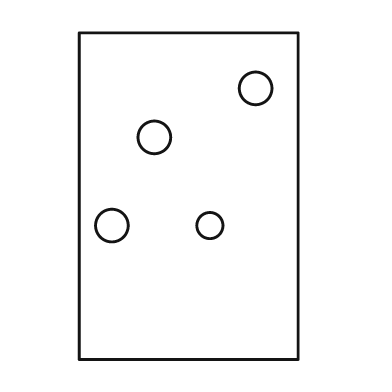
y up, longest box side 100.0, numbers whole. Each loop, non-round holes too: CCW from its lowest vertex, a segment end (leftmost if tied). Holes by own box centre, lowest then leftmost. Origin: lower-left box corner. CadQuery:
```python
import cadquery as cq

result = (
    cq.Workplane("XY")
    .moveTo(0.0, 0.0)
    .lineTo(67.0, 0.0)
    .lineTo(67.0, 100.0)
    .lineTo(0.0, 100.0)
    .close()
    .moveTo(10.0, 41.0)
    .circle(5.0)
    .moveTo(40.0, 41.0)
    .circle(4.0)
    .moveTo(23.0, 68.0)
    .circle(5.0)
    .moveTo(54.0, 83.0)
    .circle(5.0)
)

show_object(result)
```